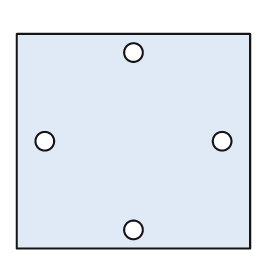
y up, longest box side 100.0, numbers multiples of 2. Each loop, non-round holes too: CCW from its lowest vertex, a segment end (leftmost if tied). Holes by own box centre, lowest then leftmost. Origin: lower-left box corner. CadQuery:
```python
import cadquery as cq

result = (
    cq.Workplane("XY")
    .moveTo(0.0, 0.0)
    .lineTo(100.0, 0.0)
    .lineTo(100.0, 92.0)
    .lineTo(0.0, 92.0)
    .close()
    .moveTo(50.0, 8.0)
    .circle(4.0)
    .moveTo(12.0, 46.0)
    .circle(4.0)
    .moveTo(88.0, 46.0)
    .circle(4.0)
    .moveTo(50.0, 84.0)
    .circle(4.0)
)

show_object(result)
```